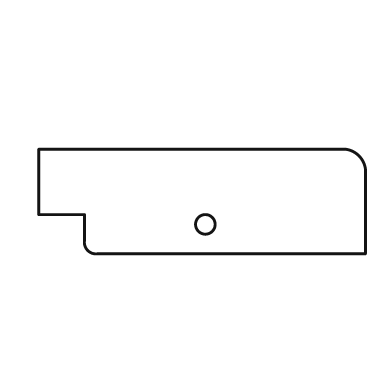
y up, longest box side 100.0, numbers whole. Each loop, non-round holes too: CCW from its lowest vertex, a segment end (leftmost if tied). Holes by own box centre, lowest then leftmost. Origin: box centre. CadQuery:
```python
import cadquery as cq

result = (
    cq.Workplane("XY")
    .moveTo(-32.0, -16.0)
    .lineTo(50.0, -16.0)
    .lineTo(50.0, 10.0)
    .threePointArc((48.0, 14.0), (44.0, 16.0))
    .lineTo(-50.0, 16.0)
    .lineTo(-50.0, -4.0)
    .lineTo(-36.0, -4.0)
    .lineTo(-36.0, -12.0)
    .threePointArc((-35.0, -15.0), (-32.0, -16.0))
    .close()
    .moveTo(1.0, -7.0)
    .circle(3.0)
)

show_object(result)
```